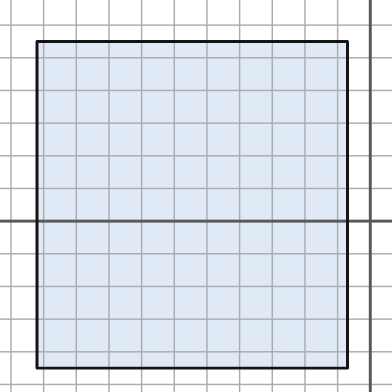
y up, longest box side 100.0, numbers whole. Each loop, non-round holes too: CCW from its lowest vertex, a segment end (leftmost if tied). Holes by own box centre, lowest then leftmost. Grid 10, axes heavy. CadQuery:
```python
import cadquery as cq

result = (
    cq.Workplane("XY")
    .moveTo(-102.0, -45.0)
    .lineTo(-7.0, -45.0)
    .lineTo(-7.0, 55.0)
    .lineTo(-102.0, 55.0)
    .close()
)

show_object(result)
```